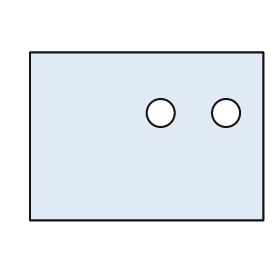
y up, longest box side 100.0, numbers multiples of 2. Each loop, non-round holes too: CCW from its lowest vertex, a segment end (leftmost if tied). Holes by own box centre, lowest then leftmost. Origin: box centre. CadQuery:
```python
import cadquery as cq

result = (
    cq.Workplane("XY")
    .moveTo(-50.0, -36.0)
    .lineTo(50.0, -36.0)
    .lineTo(50.0, 36.0)
    .lineTo(-50.0, 36.0)
    .close()
    .moveTo(6.0, 10.0)
    .circle(6.0)
    .moveTo(34.0, 10.0)
    .circle(6.0)
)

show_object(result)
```